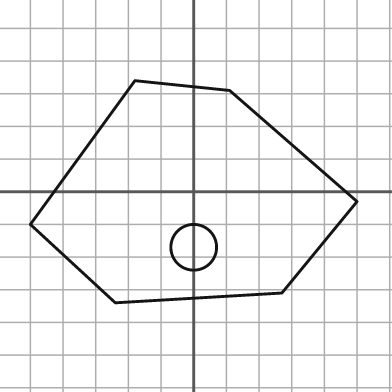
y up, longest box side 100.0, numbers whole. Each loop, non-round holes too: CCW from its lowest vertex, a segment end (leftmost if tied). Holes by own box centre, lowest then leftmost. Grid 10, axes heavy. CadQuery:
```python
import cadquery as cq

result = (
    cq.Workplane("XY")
    .moveTo(-24.0, -34.0)
    .lineTo(27.0, -31.0)
    .lineTo(50.0, -3.0)
    .lineTo(11.0, 31.0)
    .lineTo(-18.0, 34.0)
    .lineTo(-50.0, -10.0)
    .close()
    .moveTo(0.0, -17.0)
    .circle(7.0)
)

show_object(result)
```